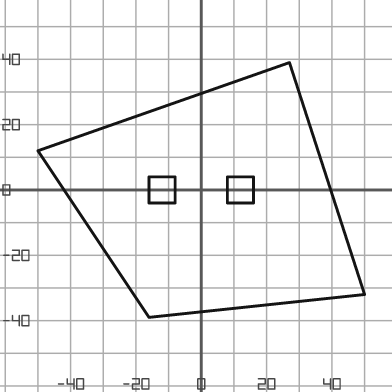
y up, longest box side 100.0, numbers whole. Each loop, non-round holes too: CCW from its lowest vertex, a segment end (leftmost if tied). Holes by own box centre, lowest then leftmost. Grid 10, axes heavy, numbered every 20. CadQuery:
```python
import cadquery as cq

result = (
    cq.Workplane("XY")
    .moveTo(-16.0, -39.0)
    .lineTo(50.0, -32.0)
    .lineTo(27.0, 39.0)
    .lineTo(-50.0, 12.0)
    .close()
    .moveTo(-16.0, -4.0)
    .lineTo(-8.0, -4.0)
    .lineTo(-8.0, 4.0)
    .lineTo(-16.0, 4.0)
    .close()
    .moveTo(8.0, -4.0)
    .lineTo(16.0, -4.0)
    .lineTo(16.0, 4.0)
    .lineTo(8.0, 4.0)
    .close()
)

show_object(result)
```